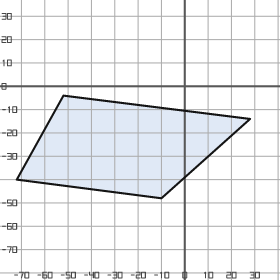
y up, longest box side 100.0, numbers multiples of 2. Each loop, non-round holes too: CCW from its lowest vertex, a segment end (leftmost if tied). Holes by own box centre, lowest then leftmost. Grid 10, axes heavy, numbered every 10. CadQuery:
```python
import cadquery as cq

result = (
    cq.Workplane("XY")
    .moveTo(-10.0, -48.0)
    .lineTo(28.0, -14.0)
    .lineTo(-52.0, -4.0)
    .lineTo(-72.0, -40.0)
    .close()
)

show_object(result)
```